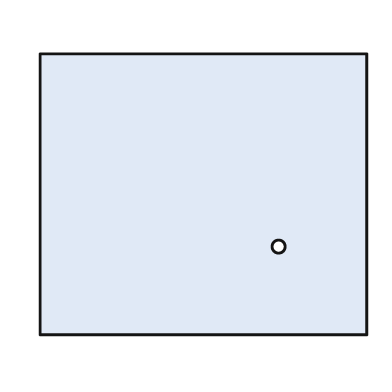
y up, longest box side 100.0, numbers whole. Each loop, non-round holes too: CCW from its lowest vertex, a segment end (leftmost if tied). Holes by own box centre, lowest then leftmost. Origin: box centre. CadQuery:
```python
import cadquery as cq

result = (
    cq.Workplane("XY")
    .moveTo(-50.0, -43.0)
    .lineTo(50.0, -43.0)
    .lineTo(50.0, 43.0)
    .lineTo(-50.0, 43.0)
    .close()
    .moveTo(23.0, -16.0)
    .circle(2.0)
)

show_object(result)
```